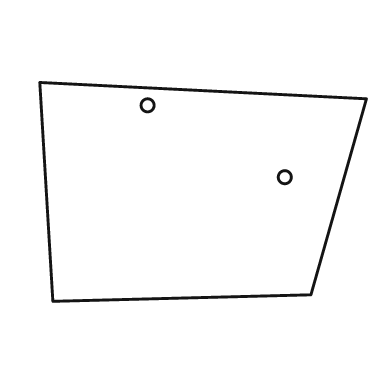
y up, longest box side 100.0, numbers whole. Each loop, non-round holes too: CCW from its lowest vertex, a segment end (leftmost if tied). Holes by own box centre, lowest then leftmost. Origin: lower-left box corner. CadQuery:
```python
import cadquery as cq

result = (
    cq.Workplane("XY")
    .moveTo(4.0, 0.0)
    .lineTo(83.0, 2.0)
    .lineTo(100.0, 62.0)
    .lineTo(0.0, 67.0)
    .close()
    .moveTo(75.0, 38.0)
    .circle(2.0)
    .moveTo(33.0, 60.0)
    .circle(2.0)
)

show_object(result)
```